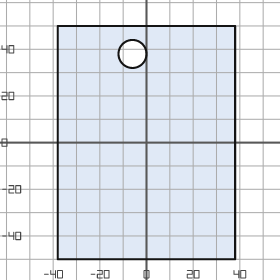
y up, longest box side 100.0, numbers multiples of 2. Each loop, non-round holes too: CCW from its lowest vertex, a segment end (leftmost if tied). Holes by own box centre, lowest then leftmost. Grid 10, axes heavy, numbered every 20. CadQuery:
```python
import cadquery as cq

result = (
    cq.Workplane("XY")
    .moveTo(-38.0, -50.0)
    .lineTo(38.0, -50.0)
    .lineTo(38.0, 50.0)
    .lineTo(-38.0, 50.0)
    .close()
    .moveTo(-6.0, 38.0)
    .circle(6.0)
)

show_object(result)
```